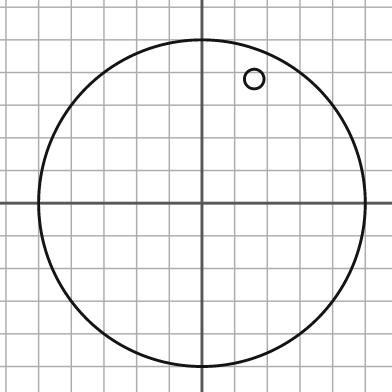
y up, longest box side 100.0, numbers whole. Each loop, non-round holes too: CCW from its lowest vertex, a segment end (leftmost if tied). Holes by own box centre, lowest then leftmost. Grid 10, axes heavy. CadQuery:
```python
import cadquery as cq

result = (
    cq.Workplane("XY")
    .moveTo(0.0, 0.0)
    .circle(50.0)
    .moveTo(16.0, 38.0)
    .circle(3.0)
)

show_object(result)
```